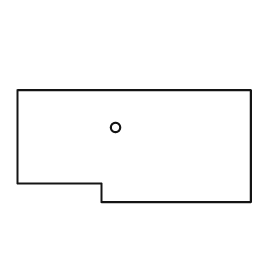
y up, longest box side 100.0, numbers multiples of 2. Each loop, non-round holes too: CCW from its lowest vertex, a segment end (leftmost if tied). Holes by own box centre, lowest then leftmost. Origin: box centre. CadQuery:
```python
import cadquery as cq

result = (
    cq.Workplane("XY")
    .moveTo(-14.0, -24.0)
    .lineTo(50.0, -24.0)
    .lineTo(50.0, 24.0)
    .lineTo(-50.0, 24.0)
    .lineTo(-50.0, -16.0)
    .lineTo(-14.0, -16.0)
    .close()
    .moveTo(-8.0, 8.0)
    .circle(2.0)
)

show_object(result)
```